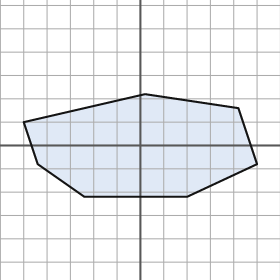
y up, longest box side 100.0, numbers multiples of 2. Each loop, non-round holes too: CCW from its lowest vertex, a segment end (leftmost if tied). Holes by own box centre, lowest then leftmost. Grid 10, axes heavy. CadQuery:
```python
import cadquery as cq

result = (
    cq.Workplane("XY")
    .moveTo(-24.0, -22.0)
    .lineTo(20.0, -22.0)
    .lineTo(50.0, -8.0)
    .lineTo(42.0, 16.0)
    .lineTo(2.0, 22.0)
    .lineTo(-50.0, 10.0)
    .lineTo(-44.0, -8.0)
    .close()
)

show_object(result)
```